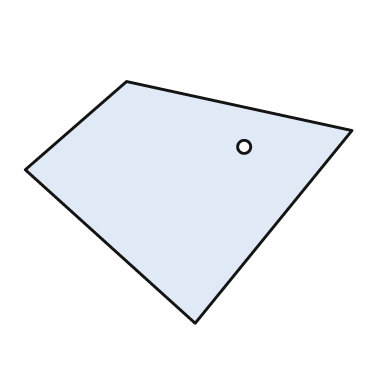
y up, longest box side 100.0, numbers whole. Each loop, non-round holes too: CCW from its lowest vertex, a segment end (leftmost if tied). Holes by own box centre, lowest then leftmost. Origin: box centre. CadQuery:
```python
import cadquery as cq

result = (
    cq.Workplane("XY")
    .moveTo(2.0, -37.0)
    .lineTo(50.0, 22.0)
    .lineTo(-19.0, 37.0)
    .lineTo(-50.0, 10.0)
    .close()
    .moveTo(17.0, 17.0)
    .circle(2.0)
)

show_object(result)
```